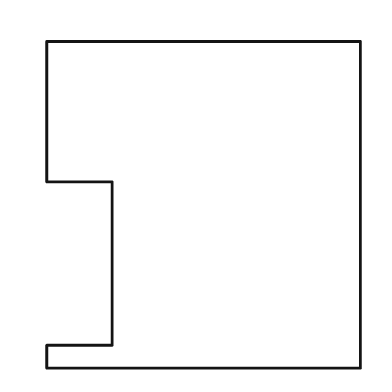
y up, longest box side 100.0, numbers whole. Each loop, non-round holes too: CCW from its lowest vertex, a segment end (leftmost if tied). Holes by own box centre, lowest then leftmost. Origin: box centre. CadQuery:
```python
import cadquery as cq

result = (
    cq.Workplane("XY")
    .moveTo(-48.0, -50.0)
    .lineTo(48.0, -50.0)
    .lineTo(48.0, 50.0)
    .lineTo(-48.0, 50.0)
    .lineTo(-48.0, 7.0)
    .lineTo(-28.0, 7.0)
    .lineTo(-28.0, -43.0)
    .lineTo(-48.0, -43.0)
    .close()
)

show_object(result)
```